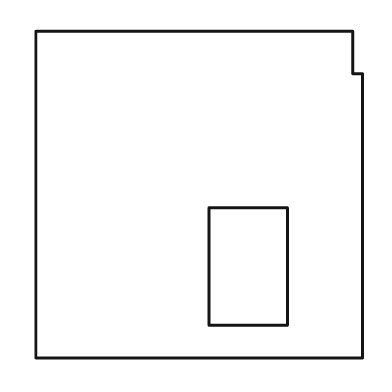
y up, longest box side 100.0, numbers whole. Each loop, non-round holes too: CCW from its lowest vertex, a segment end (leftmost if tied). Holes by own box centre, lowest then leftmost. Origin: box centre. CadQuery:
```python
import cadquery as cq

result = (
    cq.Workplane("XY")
    .moveTo(-50.0, -50.0)
    .lineTo(50.0, -50.0)
    .lineTo(50.0, 37.0)
    .lineTo(47.0, 37.0)
    .lineTo(47.0, 50.0)
    .lineTo(-50.0, 50.0)
    .close()
    .moveTo(3.0, -40.0)
    .lineTo(27.0, -40.0)
    .lineTo(27.0, -4.0)
    .lineTo(3.0, -4.0)
    .close()
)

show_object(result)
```